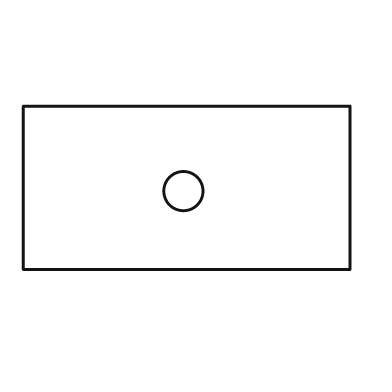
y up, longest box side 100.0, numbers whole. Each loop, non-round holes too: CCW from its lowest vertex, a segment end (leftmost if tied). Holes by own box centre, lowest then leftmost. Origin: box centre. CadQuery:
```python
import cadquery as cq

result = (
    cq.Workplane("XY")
    .moveTo(-50.0, -25.0)
    .lineTo(50.0, -25.0)
    .lineTo(50.0, 25.0)
    .lineTo(-50.0, 25.0)
    .close()
    .moveTo(-1.0, -1.0)
    .circle(6.0)
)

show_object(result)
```